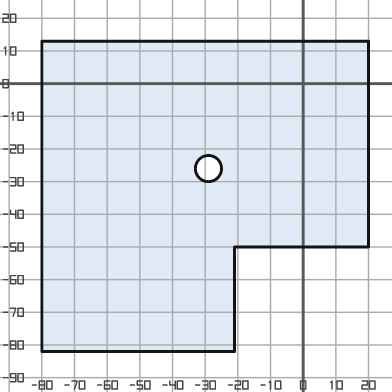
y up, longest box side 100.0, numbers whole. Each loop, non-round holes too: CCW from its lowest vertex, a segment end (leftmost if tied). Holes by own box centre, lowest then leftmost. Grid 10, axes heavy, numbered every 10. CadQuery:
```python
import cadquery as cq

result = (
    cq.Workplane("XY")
    .moveTo(-80.0, -82.0)
    .lineTo(-21.0, -82.0)
    .lineTo(-21.0, -50.0)
    .lineTo(20.0, -50.0)
    .lineTo(20.0, 13.0)
    .lineTo(-80.0, 13.0)
    .close()
    .moveTo(-29.0, -26.0)
    .circle(4.0)
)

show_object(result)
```